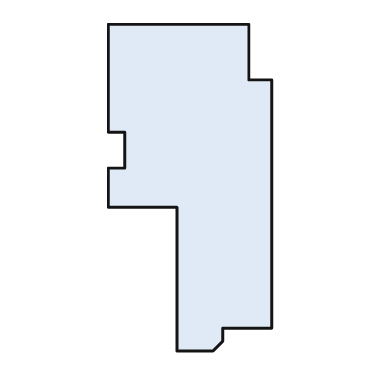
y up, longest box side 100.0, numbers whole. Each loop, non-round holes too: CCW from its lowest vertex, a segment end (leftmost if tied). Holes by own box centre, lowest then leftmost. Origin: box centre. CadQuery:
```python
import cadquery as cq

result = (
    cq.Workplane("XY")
    .moveTo(-4.0, -50.0)
    .lineTo(7.0, -50.0)
    .lineTo(10.0, -47.0)
    .lineTo(10.0, -43.0)
    .lineTo(25.0, -43.0)
    .lineTo(25.0, 33.0)
    .lineTo(18.0, 33.0)
    .lineTo(18.0, 50.0)
    .lineTo(-25.0, 50.0)
    .lineTo(-25.0, 17.0)
    .lineTo(-20.0, 17.0)
    .lineTo(-20.0, 6.0)
    .lineTo(-25.0, 6.0)
    .lineTo(-25.0, -6.0)
    .lineTo(-4.0, -6.0)
    .close()
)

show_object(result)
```